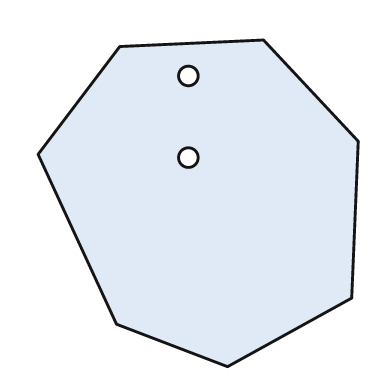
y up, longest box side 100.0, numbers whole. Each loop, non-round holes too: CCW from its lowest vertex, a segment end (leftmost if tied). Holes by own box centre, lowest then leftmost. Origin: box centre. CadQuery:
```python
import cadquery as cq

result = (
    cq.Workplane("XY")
    .moveTo(9.0, -50.0)
    .lineTo(47.0, -29.0)
    .lineTo(49.0, 19.0)
    .lineTo(20.0, 50.0)
    .lineTo(-24.0, 48.0)
    .lineTo(-49.0, 15.0)
    .lineTo(-25.0, -37.0)
    .close()
    .moveTo(-3.0, 14.0)
    .circle(3.0)
    .moveTo(-3.0, 39.0)
    .circle(3.0)
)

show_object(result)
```